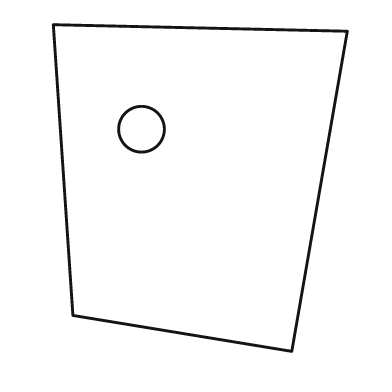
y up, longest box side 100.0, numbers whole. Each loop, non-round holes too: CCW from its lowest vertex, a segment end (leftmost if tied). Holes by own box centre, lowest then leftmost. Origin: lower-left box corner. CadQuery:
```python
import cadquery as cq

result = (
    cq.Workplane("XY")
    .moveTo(73.0, 0.0)
    .lineTo(90.0, 98.0)
    .lineTo(0.0, 100.0)
    .lineTo(6.0, 11.0)
    .close()
    .moveTo(27.0, 68.0)
    .circle(7.0)
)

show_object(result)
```